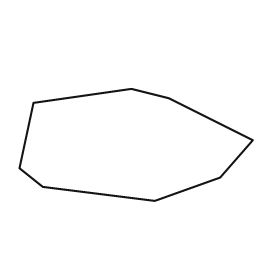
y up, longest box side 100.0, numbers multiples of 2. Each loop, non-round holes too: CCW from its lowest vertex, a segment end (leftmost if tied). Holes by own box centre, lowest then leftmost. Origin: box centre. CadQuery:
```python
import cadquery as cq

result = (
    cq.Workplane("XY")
    .moveTo(8.0, -24.0)
    .lineTo(36.0, -14.0)
    .lineTo(50.0, 2.0)
    .lineTo(14.0, 20.0)
    .lineTo(-2.0, 24.0)
    .lineTo(-44.0, 18.0)
    .lineTo(-50.0, -10.0)
    .lineTo(-40.0, -18.0)
    .close()
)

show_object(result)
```